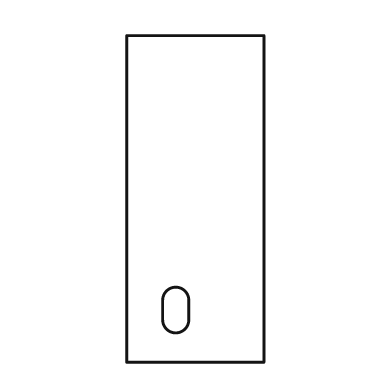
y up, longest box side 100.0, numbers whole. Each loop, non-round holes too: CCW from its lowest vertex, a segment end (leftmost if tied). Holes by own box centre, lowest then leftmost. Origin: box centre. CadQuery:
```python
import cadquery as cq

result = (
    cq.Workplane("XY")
    .moveTo(-21.0, -50.0)
    .lineTo(21.0, -50.0)
    .lineTo(21.0, 50.0)
    .lineTo(-21.0, 50.0)
    .close()
    .moveTo(-10.0, -37.0)
    .threePointArc((-6.0, -41.0), (-2.0, -37.0))
    .lineTo(-2.0, -31.0)
    .threePointArc((-6.0, -27.0), (-10.0, -31.0))
    .close()
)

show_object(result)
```